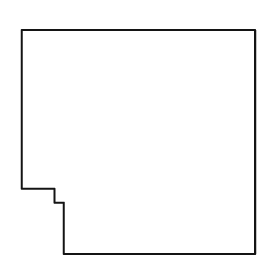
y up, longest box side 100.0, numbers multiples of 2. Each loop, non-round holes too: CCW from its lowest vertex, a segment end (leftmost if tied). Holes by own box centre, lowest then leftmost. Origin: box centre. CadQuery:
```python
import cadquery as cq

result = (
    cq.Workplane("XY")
    .moveTo(-32.0, -48.0)
    .lineTo(50.0, -48.0)
    .lineTo(50.0, 48.0)
    .lineTo(-50.0, 48.0)
    .lineTo(-50.0, -20.0)
    .lineTo(-36.0, -20.0)
    .lineTo(-36.0, -26.0)
    .lineTo(-32.0, -26.0)
    .close()
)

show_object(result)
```